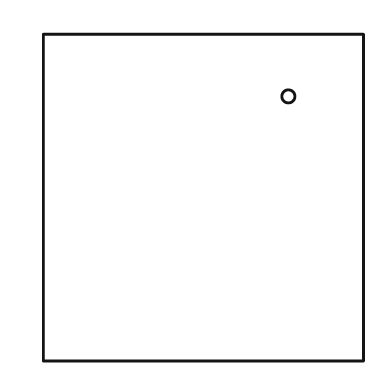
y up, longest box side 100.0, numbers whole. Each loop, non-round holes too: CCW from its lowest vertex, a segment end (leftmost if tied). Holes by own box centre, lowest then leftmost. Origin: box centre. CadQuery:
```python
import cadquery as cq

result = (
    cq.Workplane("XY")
    .moveTo(-49.0, -50.0)
    .lineTo(49.0, -50.0)
    .lineTo(49.0, 50.0)
    .lineTo(-49.0, 50.0)
    .close()
    .moveTo(26.0, 31.0)
    .circle(2.0)
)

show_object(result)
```